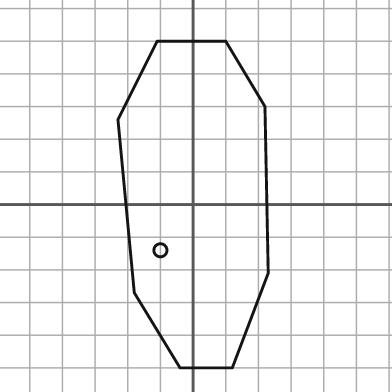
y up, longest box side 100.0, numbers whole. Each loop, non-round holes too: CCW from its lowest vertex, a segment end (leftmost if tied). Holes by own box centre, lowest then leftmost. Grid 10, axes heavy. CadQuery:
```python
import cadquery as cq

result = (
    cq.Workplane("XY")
    .moveTo(-4.0, -50.0)
    .lineTo(12.0, -50.0)
    .lineTo(23.0, -21.0)
    .lineTo(22.0, 30.0)
    .lineTo(10.0, 50.0)
    .lineTo(-11.0, 50.0)
    .lineTo(-23.0, 26.0)
    .lineTo(-18.0, -27.0)
    .close()
    .moveTo(-10.0, -14.0)
    .circle(2.0)
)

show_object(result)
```